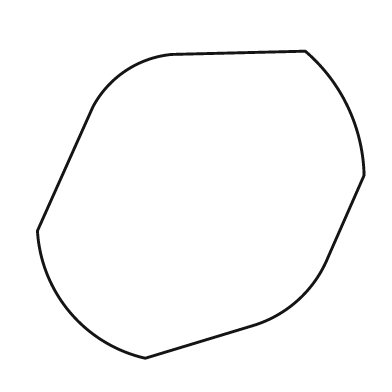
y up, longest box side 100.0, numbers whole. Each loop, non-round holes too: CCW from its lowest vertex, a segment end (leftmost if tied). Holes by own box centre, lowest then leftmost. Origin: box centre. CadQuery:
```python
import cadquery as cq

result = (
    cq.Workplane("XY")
    .moveTo(-17.0, -47.0)
    .lineTo(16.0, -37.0)
    .threePointArc((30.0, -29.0), (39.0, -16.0))
    .lineTo(50.0, 9.0)
    .threePointArc((45.0, 30.0), (32.0, 47.0))
    .lineTo(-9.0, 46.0)
    .threePointArc((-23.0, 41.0), (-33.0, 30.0))
    .lineTo(-50.0, -8.0)
    .threePointArc((-40.0, -33.0), (-17.0, -47.0))
    .close()
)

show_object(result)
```